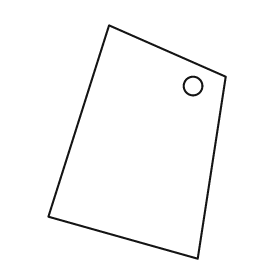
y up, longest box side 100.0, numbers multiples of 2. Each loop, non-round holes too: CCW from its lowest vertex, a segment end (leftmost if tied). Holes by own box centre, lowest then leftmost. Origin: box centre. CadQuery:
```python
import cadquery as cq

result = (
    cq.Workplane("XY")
    .moveTo(26.0, -50.0)
    .lineTo(38.0, 28.0)
    .lineTo(-12.0, 50.0)
    .lineTo(-38.0, -32.0)
    .close()
    .moveTo(24.0, 24.0)
    .circle(4.0)
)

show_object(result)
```